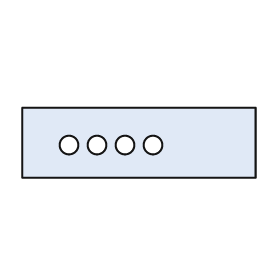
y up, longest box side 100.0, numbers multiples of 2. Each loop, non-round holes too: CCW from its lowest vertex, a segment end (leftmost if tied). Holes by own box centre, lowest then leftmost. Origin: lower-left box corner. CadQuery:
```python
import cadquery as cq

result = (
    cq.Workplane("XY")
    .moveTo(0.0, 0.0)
    .lineTo(100.0, 0.0)
    .lineTo(100.0, 30.0)
    .lineTo(0.0, 30.0)
    .close()
    .moveTo(20.0, 14.0)
    .circle(4.0)
    .moveTo(32.0, 14.0)
    .circle(4.0)
    .moveTo(44.0, 14.0)
    .circle(4.0)
    .moveTo(56.0, 14.0)
    .circle(4.0)
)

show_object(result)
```